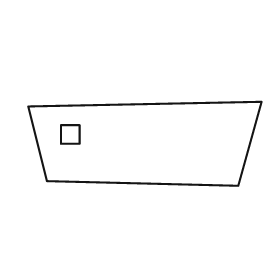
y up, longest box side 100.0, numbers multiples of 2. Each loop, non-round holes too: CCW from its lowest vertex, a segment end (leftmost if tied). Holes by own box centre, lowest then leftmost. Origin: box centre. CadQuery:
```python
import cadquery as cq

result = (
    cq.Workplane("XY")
    .moveTo(40.0, -18.0)
    .lineTo(50.0, 18.0)
    .lineTo(-50.0, 16.0)
    .lineTo(-42.0, -16.0)
    .close()
    .moveTo(-36.0, 0.0)
    .lineTo(-28.0, 0.0)
    .lineTo(-28.0, 8.0)
    .lineTo(-36.0, 8.0)
    .close()
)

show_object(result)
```